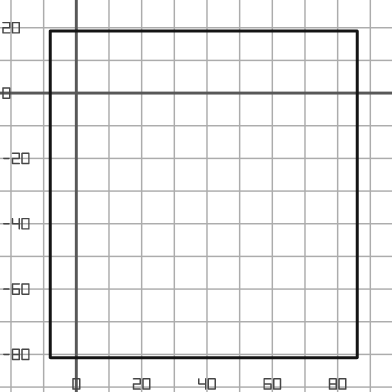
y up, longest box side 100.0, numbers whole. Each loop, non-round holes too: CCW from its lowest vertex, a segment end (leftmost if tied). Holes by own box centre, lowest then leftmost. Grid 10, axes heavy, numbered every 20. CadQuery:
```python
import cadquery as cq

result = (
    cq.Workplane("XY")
    .moveTo(-8.0, -81.0)
    .lineTo(86.0, -81.0)
    .lineTo(86.0, 19.0)
    .lineTo(-8.0, 19.0)
    .close()
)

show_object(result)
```